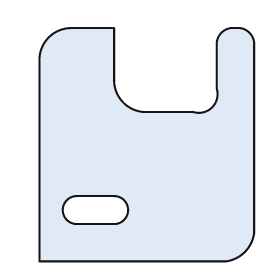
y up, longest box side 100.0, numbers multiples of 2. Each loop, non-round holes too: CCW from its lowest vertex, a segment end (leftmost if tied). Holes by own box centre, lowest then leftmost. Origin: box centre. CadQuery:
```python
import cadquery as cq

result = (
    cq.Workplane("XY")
    .moveTo(-46.0, -50.0)
    .lineTo(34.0, -50.0)
    .threePointArc((42.0, -46.0), (46.0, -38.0))
    .lineTo(46.0, 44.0)
    .threePointArc((44.0, 48.0), (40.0, 50.0))
    .lineTo(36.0, 50.0)
    .threePointArc((32.0, 48.0), (30.0, 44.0))
    .lineTo(30.0, 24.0)
    .threePointArc((28.0, 16.0), (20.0, 14.0))
    .lineTo(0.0, 14.0)
    .threePointArc((-10.0, 18.0), (-14.0, 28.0))
    .lineTo(-14.0, 50.0)
    .lineTo(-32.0, 50.0)
    .threePointArc((-42.0, 46.0), (-46.0, 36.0))
    .close()
    .moveTo(-30.0, -34.0)
    .lineTo(-14.0, -34.0)
    .threePointArc((-8.0, -28.0), (-14.0, -22.0))
    .lineTo(-30.0, -22.0)
    .threePointArc((-36.0, -28.0), (-30.0, -34.0))
    .close()
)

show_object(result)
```